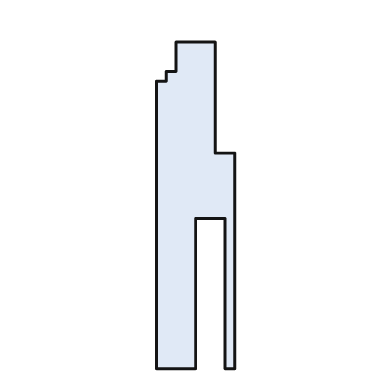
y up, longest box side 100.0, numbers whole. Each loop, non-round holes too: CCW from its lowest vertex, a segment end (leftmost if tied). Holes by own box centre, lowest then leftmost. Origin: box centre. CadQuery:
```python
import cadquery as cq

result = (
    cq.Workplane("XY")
    .moveTo(-12.0, -50.0)
    .lineTo(0.0, -50.0)
    .lineTo(0.0, -4.0)
    .lineTo(9.0, -4.0)
    .lineTo(9.0, -50.0)
    .lineTo(12.0, -50.0)
    .lineTo(12.0, 16.0)
    .lineTo(6.0, 16.0)
    .lineTo(6.0, 50.0)
    .lineTo(-6.0, 50.0)
    .lineTo(-6.0, 41.0)
    .lineTo(-9.0, 41.0)
    .lineTo(-9.0, 38.0)
    .lineTo(-12.0, 38.0)
    .close()
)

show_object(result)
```